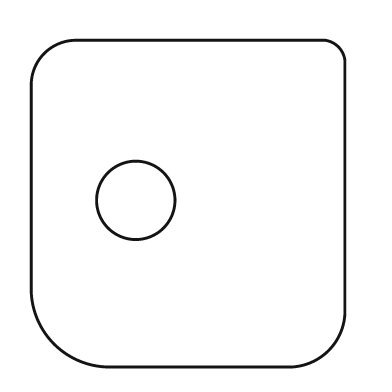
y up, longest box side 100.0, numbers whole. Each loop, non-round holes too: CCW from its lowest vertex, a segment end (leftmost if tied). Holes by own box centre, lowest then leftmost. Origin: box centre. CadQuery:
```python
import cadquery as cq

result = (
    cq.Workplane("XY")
    .moveTo(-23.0, -50.0)
    .lineTo(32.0, -50.0)
    .threePointArc((43.0, -45.0), (48.0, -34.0))
    .lineTo(48.0, 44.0)
    .threePointArc((46.0, 48.0), (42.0, 50.0))
    .lineTo(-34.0, 50.0)
    .threePointArc((-44.0, 46.0), (-48.0, 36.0))
    .lineTo(-48.0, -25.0)
    .threePointArc((-41.0, -43.0), (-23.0, -50.0))
    .close()
    .moveTo(-16.0, 1.0)
    .circle(12.0)
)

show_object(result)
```